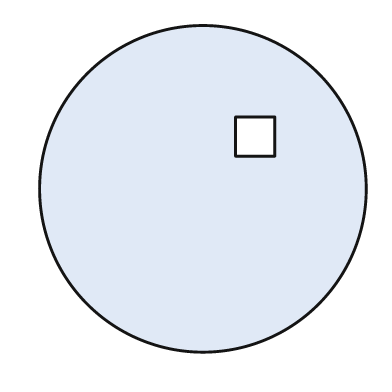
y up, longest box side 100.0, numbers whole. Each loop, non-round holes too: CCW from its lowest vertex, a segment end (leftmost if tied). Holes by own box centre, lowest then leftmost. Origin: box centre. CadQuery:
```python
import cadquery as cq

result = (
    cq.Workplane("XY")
    .moveTo(0.0, 0.0)
    .circle(50.0)
    .moveTo(10.0, 10.0)
    .lineTo(22.0, 10.0)
    .lineTo(22.0, 22.0)
    .lineTo(10.0, 22.0)
    .close()
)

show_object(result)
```